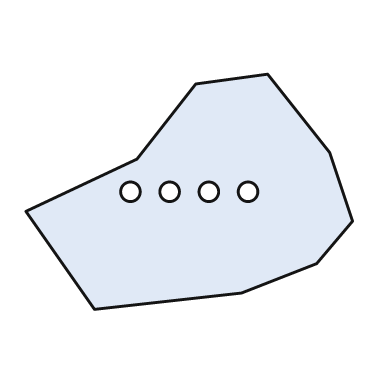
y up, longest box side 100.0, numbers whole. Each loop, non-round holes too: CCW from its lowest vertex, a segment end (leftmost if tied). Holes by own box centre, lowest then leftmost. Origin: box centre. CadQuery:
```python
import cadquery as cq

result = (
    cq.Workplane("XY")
    .moveTo(-29.0, -36.0)
    .lineTo(16.0, -31.0)
    .lineTo(39.0, -22.0)
    .lineTo(50.0, -9.0)
    .lineTo(43.0, 12.0)
    .lineTo(24.0, 36.0)
    .lineTo(2.0, 33.0)
    .lineTo(-16.0, 10.0)
    .lineTo(-50.0, -6.0)
    .close()
    .moveTo(-18.0, 0.0)
    .circle(3.0)
    .moveTo(-6.0, 0.0)
    .circle(3.0)
    .moveTo(6.0, 0.0)
    .circle(3.0)
    .moveTo(18.0, 0.0)
    .circle(3.0)
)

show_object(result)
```